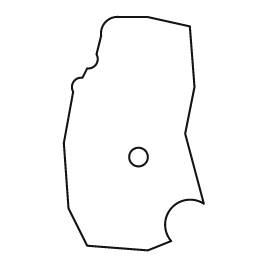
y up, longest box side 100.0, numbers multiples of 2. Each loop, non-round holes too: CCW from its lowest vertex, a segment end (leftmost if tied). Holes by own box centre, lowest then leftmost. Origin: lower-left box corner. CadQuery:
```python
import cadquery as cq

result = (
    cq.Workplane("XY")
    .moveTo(36.0, 0.0)
    .lineTo(46.0, 4.0)
    .threePointArc((46.0, 18.0), (60.0, 20.0))
    .lineTo(52.0, 50.0)
    .lineTo(56.0, 70.0)
    .lineTo(54.0, 96.0)
    .lineTo(36.0, 100.0)
    .lineTo(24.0, 100.0)
    .threePointArc((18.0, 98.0), (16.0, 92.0))
    .lineTo(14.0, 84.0)
    .threePointArc((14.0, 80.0), (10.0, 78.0))
    .lineTo(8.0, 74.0)
    .threePointArc((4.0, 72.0), (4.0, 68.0))
    .lineTo(0.0, 46.0)
    .lineTo(2.0, 18.0)
    .lineTo(10.0, 2.0)
    .close()
    .moveTo(32.0, 40.0)
    .circle(4.0)
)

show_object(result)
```